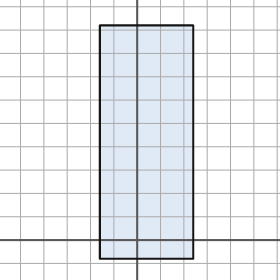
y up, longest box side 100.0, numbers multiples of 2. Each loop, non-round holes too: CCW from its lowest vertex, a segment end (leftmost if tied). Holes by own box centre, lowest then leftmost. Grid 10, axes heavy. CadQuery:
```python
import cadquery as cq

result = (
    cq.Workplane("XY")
    .moveTo(-16.0, -8.0)
    .lineTo(24.0, -8.0)
    .lineTo(24.0, 92.0)
    .lineTo(-16.0, 92.0)
    .close()
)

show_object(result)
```